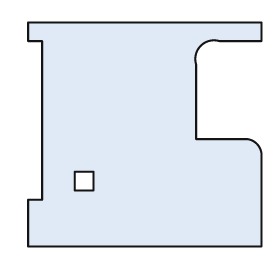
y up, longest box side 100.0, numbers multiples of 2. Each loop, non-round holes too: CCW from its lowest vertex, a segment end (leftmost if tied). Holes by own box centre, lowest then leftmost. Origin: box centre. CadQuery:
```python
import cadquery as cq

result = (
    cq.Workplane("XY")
    .moveTo(-50.0, -48.0)
    .lineTo(50.0, -48.0)
    .lineTo(50.0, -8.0)
    .threePointArc((48.0, -4.0), (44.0, -2.0))
    .lineTo(22.0, -2.0)
    .lineTo(22.0, 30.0)
    .threePointArc((24.0, 38.0), (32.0, 40.0))
    .lineTo(50.0, 40.0)
    .lineTo(50.0, 48.0)
    .lineTo(-50.0, 48.0)
    .lineTo(-50.0, 40.0)
    .lineTo(-44.0, 40.0)
    .lineTo(-44.0, -28.0)
    .lineTo(-50.0, -28.0)
    .close()
    .moveTo(-30.0, -24.0)
    .lineTo(-22.0, -24.0)
    .lineTo(-22.0, -16.0)
    .lineTo(-30.0, -16.0)
    .close()
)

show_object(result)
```